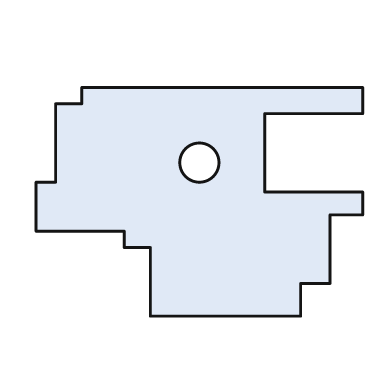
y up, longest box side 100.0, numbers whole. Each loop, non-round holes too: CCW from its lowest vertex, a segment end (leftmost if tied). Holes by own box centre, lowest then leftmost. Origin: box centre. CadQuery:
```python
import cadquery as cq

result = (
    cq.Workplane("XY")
    .moveTo(-15.0, -35.0)
    .lineTo(31.0, -35.0)
    .lineTo(31.0, -25.0)
    .lineTo(40.0, -25.0)
    .lineTo(40.0, -4.0)
    .lineTo(50.0, -4.0)
    .lineTo(50.0, 3.0)
    .lineTo(20.0, 3.0)
    .lineTo(20.0, 27.0)
    .lineTo(50.0, 27.0)
    .lineTo(50.0, 35.0)
    .lineTo(-36.0, 35.0)
    .lineTo(-36.0, 30.0)
    .lineTo(-44.0, 30.0)
    .lineTo(-44.0, 6.0)
    .lineTo(-50.0, 6.0)
    .lineTo(-50.0, -9.0)
    .lineTo(-23.0, -9.0)
    .lineTo(-23.0, -14.0)
    .lineTo(-15.0, -14.0)
    .close()
    .moveTo(0.0, 12.0)
    .circle(6.0)
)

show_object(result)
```